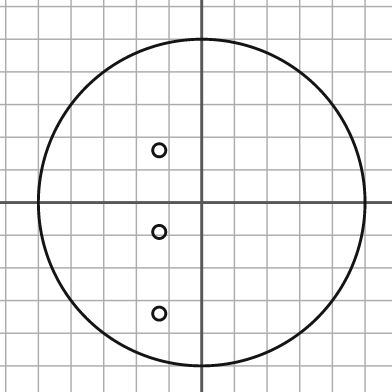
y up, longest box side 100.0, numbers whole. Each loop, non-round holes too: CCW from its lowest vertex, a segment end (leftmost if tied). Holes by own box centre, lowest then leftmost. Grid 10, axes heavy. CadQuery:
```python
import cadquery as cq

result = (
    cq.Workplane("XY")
    .moveTo(0.0, 0.0)
    .circle(50.0)
    .moveTo(-13.0, -34.0)
    .circle(2.0)
    .moveTo(-13.0, -9.0)
    .circle(2.0)
    .moveTo(-13.0, 16.0)
    .circle(2.0)
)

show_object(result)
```